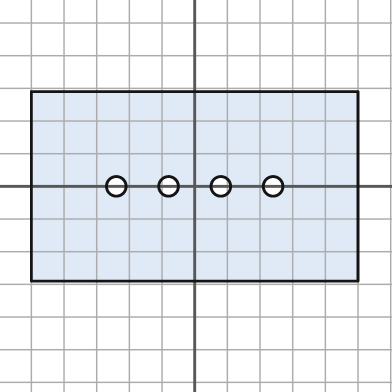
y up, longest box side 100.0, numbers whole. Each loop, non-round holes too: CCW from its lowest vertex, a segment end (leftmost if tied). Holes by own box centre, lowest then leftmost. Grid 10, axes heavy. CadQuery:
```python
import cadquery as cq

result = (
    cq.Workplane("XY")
    .moveTo(-50.0, -29.0)
    .lineTo(50.0, -29.0)
    .lineTo(50.0, 29.0)
    .lineTo(-50.0, 29.0)
    .close()
    .moveTo(-24.0, 0.0)
    .circle(3.0)
    .moveTo(-8.0, 0.0)
    .circle(3.0)
    .moveTo(8.0, 0.0)
    .circle(3.0)
    .moveTo(24.0, 0.0)
    .circle(3.0)
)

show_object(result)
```